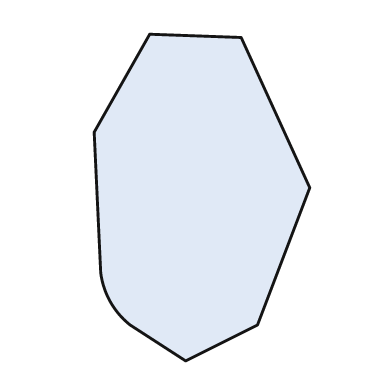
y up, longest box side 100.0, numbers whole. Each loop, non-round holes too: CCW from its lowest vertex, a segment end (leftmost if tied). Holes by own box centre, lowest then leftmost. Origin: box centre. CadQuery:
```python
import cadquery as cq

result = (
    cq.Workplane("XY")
    .moveTo(-5.0, -50.0)
    .lineTo(17.0, -39.0)
    .lineTo(33.0, 3.0)
    .lineTo(12.0, 49.0)
    .lineTo(-16.0, 50.0)
    .lineTo(-33.0, 20.0)
    .lineTo(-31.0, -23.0)
    .threePointArc((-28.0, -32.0), (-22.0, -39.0))
    .close()
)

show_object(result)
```